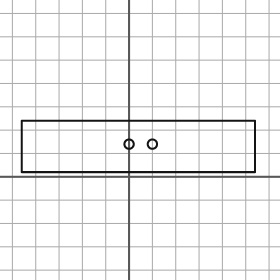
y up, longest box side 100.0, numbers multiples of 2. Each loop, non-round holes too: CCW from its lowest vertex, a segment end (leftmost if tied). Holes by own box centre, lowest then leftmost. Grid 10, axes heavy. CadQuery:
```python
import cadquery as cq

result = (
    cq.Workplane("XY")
    .moveTo(-46.0, 2.0)
    .lineTo(54.0, 2.0)
    .lineTo(54.0, 24.0)
    .lineTo(-46.0, 24.0)
    .close()
    .moveTo(0.0, 14.0)
    .circle(2.0)
    .moveTo(10.0, 14.0)
    .circle(2.0)
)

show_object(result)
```